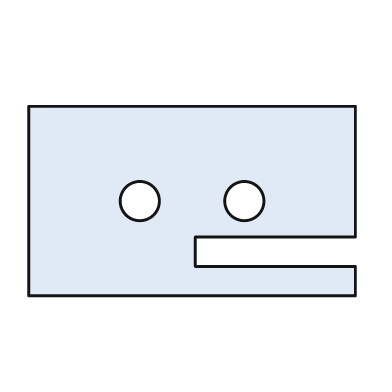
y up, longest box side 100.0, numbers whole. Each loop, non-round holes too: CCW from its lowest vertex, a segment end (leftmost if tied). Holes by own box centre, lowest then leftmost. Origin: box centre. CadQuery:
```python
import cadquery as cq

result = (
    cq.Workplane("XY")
    .moveTo(-50.0, -29.0)
    .lineTo(50.0, -29.0)
    .lineTo(50.0, -20.0)
    .lineTo(1.0, -20.0)
    .lineTo(1.0, -11.0)
    .lineTo(50.0, -11.0)
    .lineTo(50.0, 29.0)
    .lineTo(-50.0, 29.0)
    .close()
    .moveTo(-16.0, 0.0)
    .circle(6.0)
    .moveTo(16.0, 0.0)
    .circle(6.0)
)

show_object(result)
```